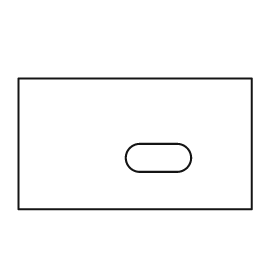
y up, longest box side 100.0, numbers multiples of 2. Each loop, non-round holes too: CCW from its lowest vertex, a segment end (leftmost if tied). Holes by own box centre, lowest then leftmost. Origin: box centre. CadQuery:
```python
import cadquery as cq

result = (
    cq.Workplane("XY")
    .moveTo(-50.0, -28.0)
    .lineTo(50.0, -28.0)
    .lineTo(50.0, 28.0)
    .lineTo(-50.0, 28.0)
    .close()
    .moveTo(2.0, -12.0)
    .lineTo(18.0, -12.0)
    .threePointArc((24.0, -6.0), (18.0, 0.0))
    .lineTo(2.0, 0.0)
    .threePointArc((-4.0, -6.0), (2.0, -12.0))
    .close()
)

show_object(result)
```